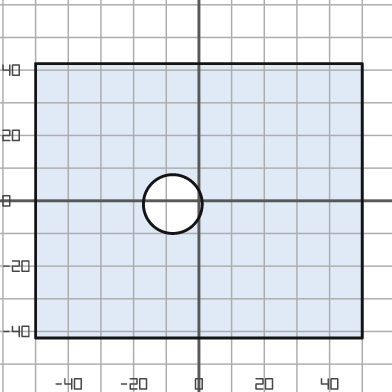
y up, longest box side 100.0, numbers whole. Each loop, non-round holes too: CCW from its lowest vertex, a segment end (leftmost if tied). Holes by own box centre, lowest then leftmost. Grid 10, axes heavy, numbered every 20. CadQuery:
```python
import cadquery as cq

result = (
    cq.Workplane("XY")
    .moveTo(-50.0, -42.0)
    .lineTo(50.0, -42.0)
    .lineTo(50.0, 42.0)
    .lineTo(-50.0, 42.0)
    .close()
    .moveTo(-8.0, -1.0)
    .circle(9.0)
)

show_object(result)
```